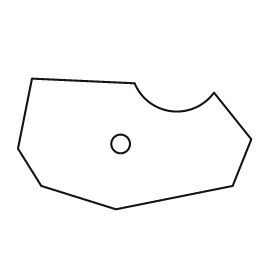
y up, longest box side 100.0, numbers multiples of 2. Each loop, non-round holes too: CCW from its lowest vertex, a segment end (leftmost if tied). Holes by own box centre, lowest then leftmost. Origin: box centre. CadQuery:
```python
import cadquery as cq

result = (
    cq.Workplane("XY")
    .moveTo(-8.0, -28.0)
    .lineTo(42.0, -18.0)
    .lineTo(50.0, 2.0)
    .lineTo(34.0, 22.0)
    .threePointArc((16.0, 14.0), (0.0, 26.0))
    .lineTo(-44.0, 28.0)
    .lineTo(-50.0, -2.0)
    .lineTo(-40.0, -18.0)
    .close()
    .moveTo(-6.0, 0.0)
    .circle(4.0)
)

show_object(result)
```